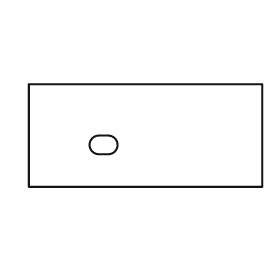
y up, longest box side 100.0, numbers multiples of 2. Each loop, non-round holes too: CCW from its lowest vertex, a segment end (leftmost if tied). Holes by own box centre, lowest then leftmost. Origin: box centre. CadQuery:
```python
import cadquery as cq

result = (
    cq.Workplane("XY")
    .moveTo(-50.0, -22.0)
    .lineTo(50.0, -22.0)
    .lineTo(50.0, 22.0)
    .lineTo(-50.0, 22.0)
    .close()
    .moveTo(-20.0, -8.0)
    .lineTo(-16.0, -8.0)
    .threePointArc((-12.0, -4.0), (-16.0, 0.0))
    .lineTo(-20.0, 0.0)
    .threePointArc((-24.0, -4.0), (-20.0, -8.0))
    .close()
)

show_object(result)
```